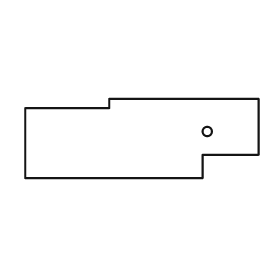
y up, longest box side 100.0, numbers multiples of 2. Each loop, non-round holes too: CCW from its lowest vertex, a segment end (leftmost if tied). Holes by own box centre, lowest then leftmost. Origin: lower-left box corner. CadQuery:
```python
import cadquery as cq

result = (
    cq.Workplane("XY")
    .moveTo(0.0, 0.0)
    .lineTo(76.0, 0.0)
    .lineTo(76.0, 10.0)
    .lineTo(100.0, 10.0)
    .lineTo(100.0, 34.0)
    .lineTo(36.0, 34.0)
    .lineTo(36.0, 30.0)
    .lineTo(0.0, 30.0)
    .close()
    .moveTo(78.0, 20.0)
    .circle(2.0)
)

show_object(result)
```